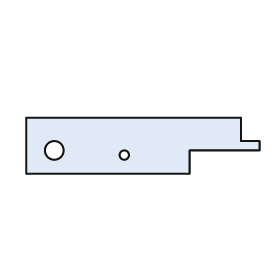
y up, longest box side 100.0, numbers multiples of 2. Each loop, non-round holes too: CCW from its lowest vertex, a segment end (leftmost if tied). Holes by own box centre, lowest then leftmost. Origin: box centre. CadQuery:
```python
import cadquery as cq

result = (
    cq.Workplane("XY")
    .moveTo(-50.0, -12.0)
    .lineTo(20.0, -12.0)
    .lineTo(20.0, -2.0)
    .lineTo(50.0, -2.0)
    .lineTo(50.0, 2.0)
    .lineTo(42.0, 2.0)
    .lineTo(42.0, 12.0)
    .lineTo(-50.0, 12.0)
    .close()
    .moveTo(-8.0, -4.0)
    .circle(2.0)
    .moveTo(-38.0, -2.0)
    .circle(4.0)
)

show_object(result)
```